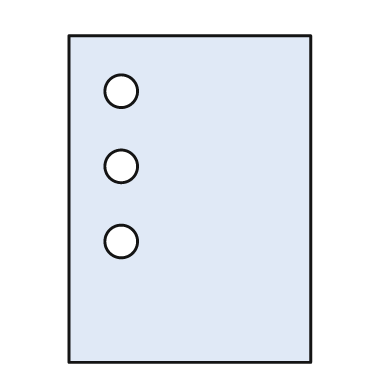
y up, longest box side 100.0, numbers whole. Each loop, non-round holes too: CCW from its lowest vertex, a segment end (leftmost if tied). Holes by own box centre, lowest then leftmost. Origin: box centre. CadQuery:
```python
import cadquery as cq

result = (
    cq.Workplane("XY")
    .moveTo(-37.0, -50.0)
    .lineTo(37.0, -50.0)
    .lineTo(37.0, 50.0)
    .lineTo(-37.0, 50.0)
    .close()
    .moveTo(-21.0, -13.0)
    .circle(5.0)
    .moveTo(-21.0, 10.0)
    .circle(5.0)
    .moveTo(-21.0, 33.0)
    .circle(5.0)
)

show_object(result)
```